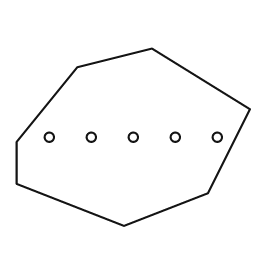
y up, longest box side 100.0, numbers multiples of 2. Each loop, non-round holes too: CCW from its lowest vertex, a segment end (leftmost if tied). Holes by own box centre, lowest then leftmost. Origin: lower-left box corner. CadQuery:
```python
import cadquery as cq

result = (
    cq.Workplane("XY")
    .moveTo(46.0, 0.0)
    .lineTo(82.0, 14.0)
    .lineTo(100.0, 50.0)
    .lineTo(58.0, 76.0)
    .lineTo(26.0, 68.0)
    .lineTo(0.0, 36.0)
    .lineTo(0.0, 18.0)
    .close()
    .moveTo(14.0, 38.0)
    .circle(2.0)
    .moveTo(32.0, 38.0)
    .circle(2.0)
    .moveTo(50.0, 38.0)
    .circle(2.0)
    .moveTo(68.0, 38.0)
    .circle(2.0)
    .moveTo(86.0, 38.0)
    .circle(2.0)
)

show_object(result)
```